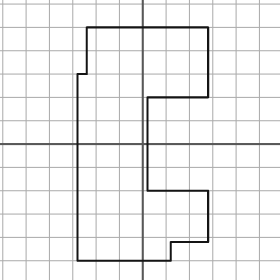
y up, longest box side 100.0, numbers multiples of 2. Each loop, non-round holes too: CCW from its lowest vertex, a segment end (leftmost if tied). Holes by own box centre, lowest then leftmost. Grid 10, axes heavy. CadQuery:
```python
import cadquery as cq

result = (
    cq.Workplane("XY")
    .moveTo(-28.0, -50.0)
    .lineTo(12.0, -50.0)
    .lineTo(12.0, -42.0)
    .lineTo(28.0, -42.0)
    .lineTo(28.0, -20.0)
    .lineTo(2.0, -20.0)
    .lineTo(2.0, 20.0)
    .lineTo(28.0, 20.0)
    .lineTo(28.0, 50.0)
    .lineTo(-24.0, 50.0)
    .lineTo(-24.0, 30.0)
    .lineTo(-28.0, 30.0)
    .close()
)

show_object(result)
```